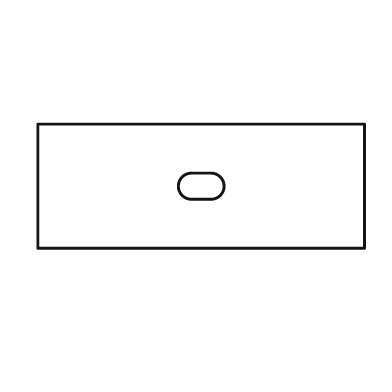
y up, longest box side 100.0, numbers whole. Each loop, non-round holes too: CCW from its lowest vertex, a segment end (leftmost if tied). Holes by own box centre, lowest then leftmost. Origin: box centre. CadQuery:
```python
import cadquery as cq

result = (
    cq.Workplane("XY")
    .moveTo(-50.0, -19.0)
    .lineTo(50.0, -19.0)
    .lineTo(50.0, 19.0)
    .lineTo(-50.0, 19.0)
    .close()
    .moveTo(-3.0, -4.0)
    .lineTo(3.0, -4.0)
    .threePointArc((7.0, 0.0), (3.0, 4.0))
    .lineTo(-3.0, 4.0)
    .threePointArc((-7.0, 0.0), (-3.0, -4.0))
    .close()
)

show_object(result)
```